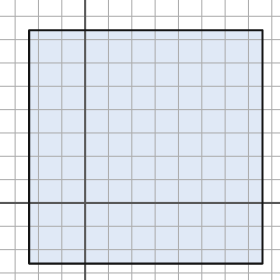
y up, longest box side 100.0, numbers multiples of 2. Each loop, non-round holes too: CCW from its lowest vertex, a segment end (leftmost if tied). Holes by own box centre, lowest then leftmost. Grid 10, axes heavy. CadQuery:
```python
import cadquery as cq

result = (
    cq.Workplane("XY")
    .moveTo(-24.0, -26.0)
    .lineTo(76.0, -26.0)
    .lineTo(76.0, 74.0)
    .lineTo(-24.0, 74.0)
    .close()
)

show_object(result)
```